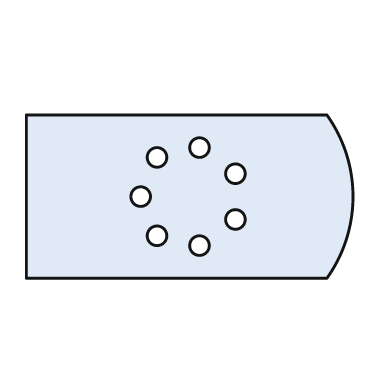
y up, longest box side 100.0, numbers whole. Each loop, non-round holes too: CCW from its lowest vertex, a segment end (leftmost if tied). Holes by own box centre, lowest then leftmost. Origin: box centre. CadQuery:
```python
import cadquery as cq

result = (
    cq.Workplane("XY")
    .moveTo(-50.0, -25.0)
    .lineTo(42.0, -25.0)
    .threePointArc((50.0, 0.0), (42.0, 25.0))
    .lineTo(-50.0, 25.0)
    .close()
    .moveTo(3.0, -15.0)
    .circle(3.0)
    .moveTo(-10.0, -12.0)
    .circle(3.0)
    .moveTo(14.0, -7.0)
    .circle(3.0)
    .moveTo(-15.0, 0.0)
    .circle(3.0)
    .moveTo(14.0, 7.0)
    .circle(3.0)
    .moveTo(-10.0, 12.0)
    .circle(3.0)
    .moveTo(3.0, 15.0)
    .circle(3.0)
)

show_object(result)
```